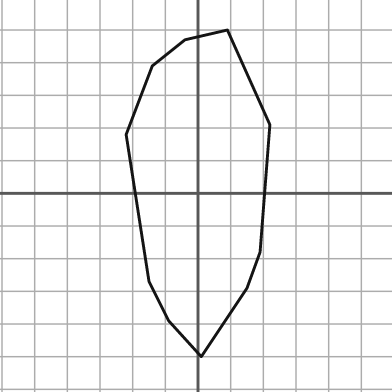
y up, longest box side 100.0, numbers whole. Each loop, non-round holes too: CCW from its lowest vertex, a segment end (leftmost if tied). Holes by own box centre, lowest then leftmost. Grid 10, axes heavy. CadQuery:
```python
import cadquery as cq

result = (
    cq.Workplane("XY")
    .moveTo(1.0, -50.0)
    .lineTo(15.0, -29.0)
    .lineTo(19.0, -18.0)
    .lineTo(22.0, 21.0)
    .lineTo(9.0, 50.0)
    .lineTo(-4.0, 47.0)
    .lineTo(-14.0, 39.0)
    .lineTo(-22.0, 18.0)
    .lineTo(-15.0, -27.0)
    .lineTo(-9.0, -39.0)
    .close()
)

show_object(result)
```